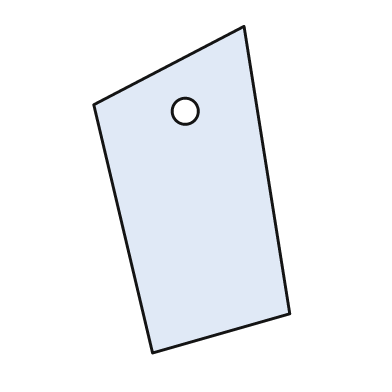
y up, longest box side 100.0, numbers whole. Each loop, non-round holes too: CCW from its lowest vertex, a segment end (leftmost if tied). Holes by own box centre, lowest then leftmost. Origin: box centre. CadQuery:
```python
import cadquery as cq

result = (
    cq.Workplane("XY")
    .moveTo(-12.0, -50.0)
    .lineTo(30.0, -38.0)
    .lineTo(16.0, 50.0)
    .lineTo(-30.0, 26.0)
    .close()
    .moveTo(-2.0, 24.0)
    .circle(4.0)
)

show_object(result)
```